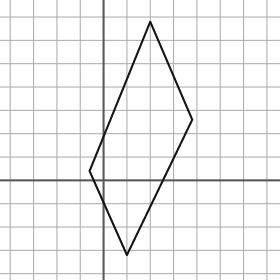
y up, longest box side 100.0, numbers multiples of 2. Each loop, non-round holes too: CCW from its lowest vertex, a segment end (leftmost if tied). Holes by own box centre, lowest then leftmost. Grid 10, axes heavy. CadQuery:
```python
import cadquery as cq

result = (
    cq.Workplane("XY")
    .moveTo(10.0, -32.0)
    .lineTo(38.0, 26.0)
    .lineTo(20.0, 68.0)
    .lineTo(-6.0, 4.0)
    .close()
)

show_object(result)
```